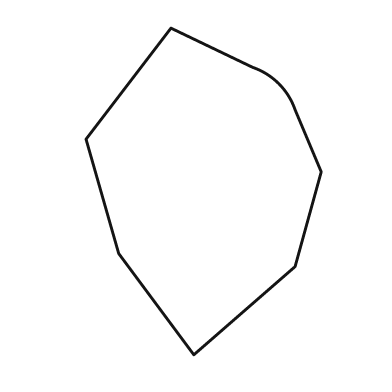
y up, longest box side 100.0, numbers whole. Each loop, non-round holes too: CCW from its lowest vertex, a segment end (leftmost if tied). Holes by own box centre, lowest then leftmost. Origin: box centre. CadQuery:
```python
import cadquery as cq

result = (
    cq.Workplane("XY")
    .moveTo(-3.0, -50.0)
    .lineTo(28.0, -23.0)
    .lineTo(36.0, 6.0)
    .lineTo(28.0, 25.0)
    .threePointArc((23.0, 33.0), (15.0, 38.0))
    .lineTo(-10.0, 50.0)
    .lineTo(-36.0, 16.0)
    .lineTo(-26.0, -19.0)
    .close()
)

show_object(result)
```